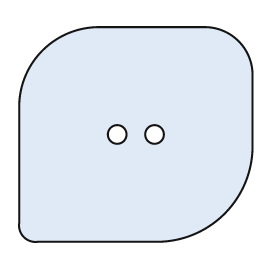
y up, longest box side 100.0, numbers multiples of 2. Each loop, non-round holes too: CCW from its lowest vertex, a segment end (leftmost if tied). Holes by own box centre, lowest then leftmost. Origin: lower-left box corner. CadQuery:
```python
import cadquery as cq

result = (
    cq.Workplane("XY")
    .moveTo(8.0, 0.0)
    .lineTo(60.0, 0.0)
    .threePointArc((88.0, 12.0), (100.0, 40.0))
    .lineTo(100.0, 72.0)
    .threePointArc((94.0, 86.0), (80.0, 92.0))
    .lineTo(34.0, 92.0)
    .threePointArc((10.0, 82.0), (0.0, 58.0))
    .lineTo(0.0, 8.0)
    .threePointArc((2.0, 2.0), (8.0, 0.0))
    .close()
    .moveTo(42.0, 46.0)
    .circle(4.0)
    .moveTo(58.0, 46.0)
    .circle(4.0)
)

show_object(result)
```